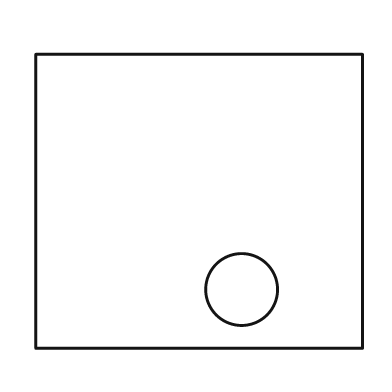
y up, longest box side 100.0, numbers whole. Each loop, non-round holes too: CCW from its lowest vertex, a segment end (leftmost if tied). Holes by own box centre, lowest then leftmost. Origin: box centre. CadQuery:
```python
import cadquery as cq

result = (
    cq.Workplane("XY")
    .moveTo(-50.0, -45.0)
    .lineTo(50.0, -45.0)
    .lineTo(50.0, 45.0)
    .lineTo(-50.0, 45.0)
    .close()
    .moveTo(13.0, -27.0)
    .circle(11.0)
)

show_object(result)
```